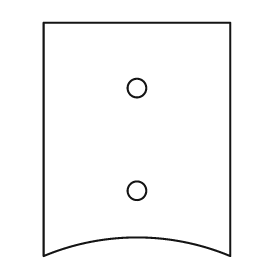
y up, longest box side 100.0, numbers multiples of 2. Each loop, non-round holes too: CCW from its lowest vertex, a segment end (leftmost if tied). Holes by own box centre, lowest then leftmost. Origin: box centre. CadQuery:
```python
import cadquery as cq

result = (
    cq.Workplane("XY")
    .moveTo(-40.0, -50.0)
    .threePointArc((0.0, -42.0), (40.0, -50.0))
    .lineTo(40.0, 50.0)
    .lineTo(-40.0, 50.0)
    .close()
    .moveTo(0.0, -22.0)
    .circle(4.0)
    .moveTo(0.0, 22.0)
    .circle(4.0)
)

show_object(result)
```